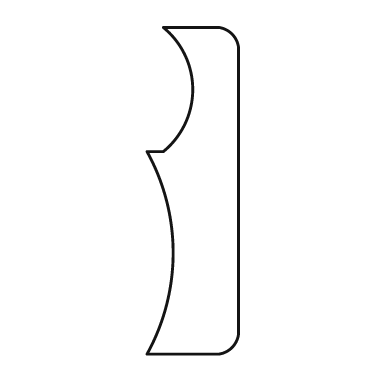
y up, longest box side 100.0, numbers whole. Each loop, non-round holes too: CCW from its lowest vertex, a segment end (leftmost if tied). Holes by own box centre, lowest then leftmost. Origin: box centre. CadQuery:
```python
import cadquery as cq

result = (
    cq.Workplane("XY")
    .moveTo(-14.0, -50.0)
    .lineTo(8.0, -50.0)
    .threePointArc((12.0, -48.0), (14.0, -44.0))
    .lineTo(14.0, 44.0)
    .threePointArc((12.0, 48.0), (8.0, 50.0))
    .lineTo(-9.0, 50.0)
    .threePointArc((0.0, 31.0), (-9.0, 12.0))
    .lineTo(-14.0, 12.0)
    .threePointArc((-6.0, -19.0), (-14.0, -50.0))
    .close()
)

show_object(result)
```